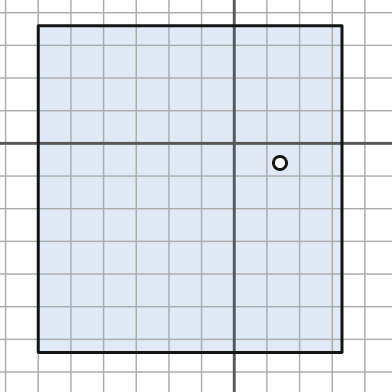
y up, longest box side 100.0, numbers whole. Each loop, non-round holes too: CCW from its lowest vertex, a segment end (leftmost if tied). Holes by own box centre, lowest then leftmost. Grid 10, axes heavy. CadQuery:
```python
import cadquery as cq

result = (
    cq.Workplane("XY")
    .moveTo(-60.0, -64.0)
    .lineTo(33.0, -64.0)
    .lineTo(33.0, 36.0)
    .lineTo(-60.0, 36.0)
    .close()
    .moveTo(14.0, -6.0)
    .circle(2.0)
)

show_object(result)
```